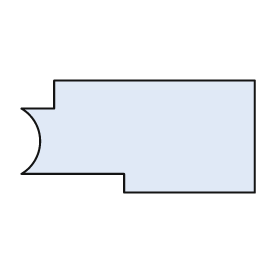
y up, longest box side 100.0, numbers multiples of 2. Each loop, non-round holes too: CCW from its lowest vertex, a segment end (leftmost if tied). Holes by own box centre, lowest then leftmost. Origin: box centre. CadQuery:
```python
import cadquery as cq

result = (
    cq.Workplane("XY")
    .moveTo(-6.0, -24.0)
    .lineTo(50.0, -24.0)
    .lineTo(50.0, 24.0)
    .lineTo(-36.0, 24.0)
    .lineTo(-36.0, 12.0)
    .lineTo(-50.0, 12.0)
    .threePointArc((-42.0, -2.0), (-50.0, -16.0))
    .lineTo(-6.0, -16.0)
    .close()
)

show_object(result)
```